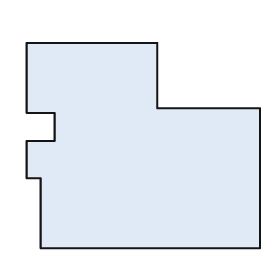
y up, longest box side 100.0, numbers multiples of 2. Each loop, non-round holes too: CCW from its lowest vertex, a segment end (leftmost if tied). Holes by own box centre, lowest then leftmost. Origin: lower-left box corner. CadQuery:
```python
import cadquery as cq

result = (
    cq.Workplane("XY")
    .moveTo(6.0, 0.0)
    .lineTo(100.0, 0.0)
    .lineTo(100.0, 60.0)
    .lineTo(56.0, 60.0)
    .lineTo(56.0, 88.0)
    .lineTo(0.0, 88.0)
    .lineTo(0.0, 58.0)
    .lineTo(12.0, 58.0)
    .lineTo(12.0, 46.0)
    .lineTo(0.0, 46.0)
    .lineTo(0.0, 30.0)
    .lineTo(6.0, 30.0)
    .close()
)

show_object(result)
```